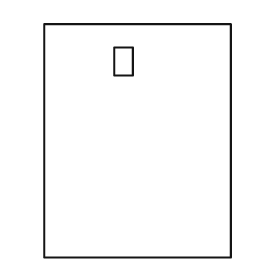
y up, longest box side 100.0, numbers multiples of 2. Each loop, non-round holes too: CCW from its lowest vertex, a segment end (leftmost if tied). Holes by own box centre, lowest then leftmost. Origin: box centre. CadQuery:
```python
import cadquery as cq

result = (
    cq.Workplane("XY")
    .moveTo(-40.0, -50.0)
    .lineTo(40.0, -50.0)
    .lineTo(40.0, 50.0)
    .lineTo(-40.0, 50.0)
    .close()
    .moveTo(-10.0, 28.0)
    .lineTo(-2.0, 28.0)
    .lineTo(-2.0, 40.0)
    .lineTo(-10.0, 40.0)
    .close()
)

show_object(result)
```